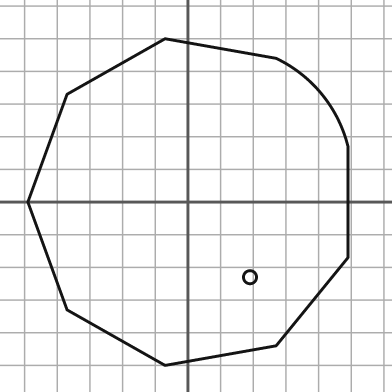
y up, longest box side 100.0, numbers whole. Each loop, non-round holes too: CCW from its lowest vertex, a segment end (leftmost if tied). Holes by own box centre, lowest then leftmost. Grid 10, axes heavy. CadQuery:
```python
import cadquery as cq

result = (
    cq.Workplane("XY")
    .moveTo(-7.0, -50.0)
    .lineTo(27.0, -44.0)
    .lineTo(49.0, -17.0)
    .lineTo(49.0, 17.0)
    .threePointArc((41.0, 33.0), (27.0, 44.0))
    .lineTo(-7.0, 50.0)
    .lineTo(-37.0, 33.0)
    .lineTo(-49.0, 0.0)
    .lineTo(-37.0, -33.0)
    .close()
    .moveTo(19.0, -23.0)
    .circle(2.0)
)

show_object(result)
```